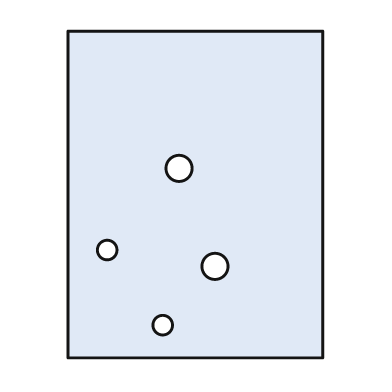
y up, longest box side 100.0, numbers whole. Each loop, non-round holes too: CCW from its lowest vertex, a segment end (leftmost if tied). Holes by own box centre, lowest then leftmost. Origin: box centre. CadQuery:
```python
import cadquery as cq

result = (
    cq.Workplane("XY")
    .moveTo(-39.0, -50.0)
    .lineTo(39.0, -50.0)
    .lineTo(39.0, 50.0)
    .lineTo(-39.0, 50.0)
    .close()
    .moveTo(-10.0, -40.0)
    .circle(3.0)
    .moveTo(6.0, -22.0)
    .circle(4.0)
    .moveTo(-27.0, -17.0)
    .circle(3.0)
    .moveTo(-5.0, 8.0)
    .circle(4.0)
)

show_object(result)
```